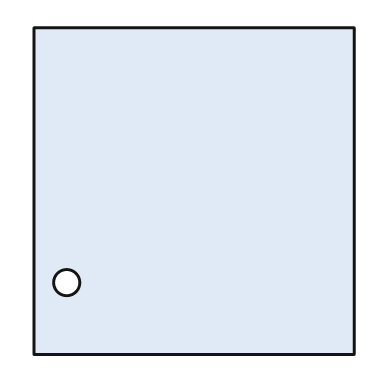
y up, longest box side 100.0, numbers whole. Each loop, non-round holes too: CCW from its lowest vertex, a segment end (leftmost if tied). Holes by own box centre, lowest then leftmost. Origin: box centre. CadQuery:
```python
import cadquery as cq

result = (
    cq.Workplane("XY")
    .moveTo(-49.0, -50.0)
    .lineTo(49.0, -50.0)
    .lineTo(49.0, 50.0)
    .lineTo(-49.0, 50.0)
    .close()
    .moveTo(-39.0, -28.0)
    .circle(4.0)
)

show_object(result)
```